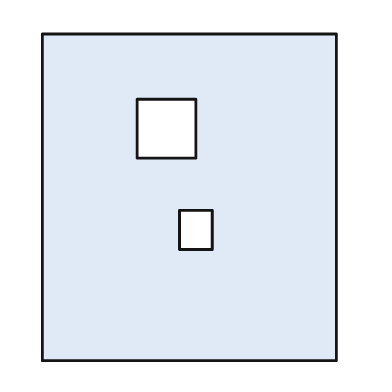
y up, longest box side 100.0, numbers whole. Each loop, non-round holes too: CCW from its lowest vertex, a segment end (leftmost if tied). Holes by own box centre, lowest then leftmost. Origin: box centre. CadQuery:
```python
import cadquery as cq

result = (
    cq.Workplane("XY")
    .moveTo(-45.0, -50.0)
    .lineTo(45.0, -50.0)
    .lineTo(45.0, 50.0)
    .lineTo(-45.0, 50.0)
    .close()
    .moveTo(-3.0, -16.0)
    .lineTo(7.0, -16.0)
    .lineTo(7.0, -4.0)
    .lineTo(-3.0, -4.0)
    .close()
    .moveTo(-16.0, 12.0)
    .lineTo(2.0, 12.0)
    .lineTo(2.0, 30.0)
    .lineTo(-16.0, 30.0)
    .close()
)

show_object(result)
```